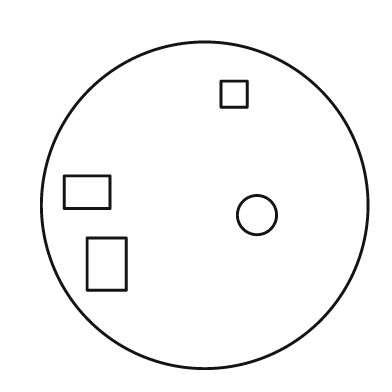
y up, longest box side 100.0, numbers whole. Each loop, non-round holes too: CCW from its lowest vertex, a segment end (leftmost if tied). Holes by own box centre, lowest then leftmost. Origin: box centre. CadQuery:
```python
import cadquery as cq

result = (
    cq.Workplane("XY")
    .moveTo(0.0, 0.0)
    .circle(50.0)
    .moveTo(-36.0, -26.0)
    .lineTo(-24.0, -26.0)
    .lineTo(-24.0, -10.0)
    .lineTo(-36.0, -10.0)
    .close()
    .moveTo(16.0, -3.0)
    .circle(6.0)
    .moveTo(-43.0, -1.0)
    .lineTo(-29.0, -1.0)
    .lineTo(-29.0, 9.0)
    .lineTo(-43.0, 9.0)
    .close()
    .moveTo(5.0, 30.0)
    .lineTo(13.0, 30.0)
    .lineTo(13.0, 38.0)
    .lineTo(5.0, 38.0)
    .close()
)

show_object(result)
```